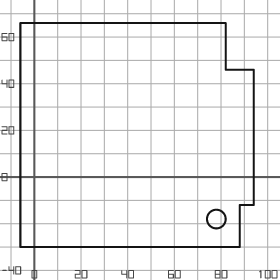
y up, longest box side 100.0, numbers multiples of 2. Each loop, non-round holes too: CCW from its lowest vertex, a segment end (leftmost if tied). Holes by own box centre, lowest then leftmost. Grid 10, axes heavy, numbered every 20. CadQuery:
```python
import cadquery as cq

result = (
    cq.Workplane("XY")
    .moveTo(-6.0, -30.0)
    .lineTo(88.0, -30.0)
    .lineTo(88.0, -12.0)
    .lineTo(94.0, -12.0)
    .lineTo(94.0, 46.0)
    .lineTo(82.0, 46.0)
    .lineTo(82.0, 66.0)
    .lineTo(-6.0, 66.0)
    .close()
    .moveTo(78.0, -18.0)
    .circle(4.0)
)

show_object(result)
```